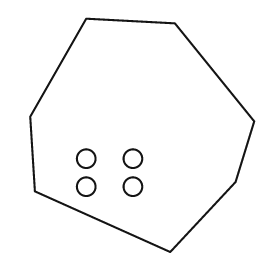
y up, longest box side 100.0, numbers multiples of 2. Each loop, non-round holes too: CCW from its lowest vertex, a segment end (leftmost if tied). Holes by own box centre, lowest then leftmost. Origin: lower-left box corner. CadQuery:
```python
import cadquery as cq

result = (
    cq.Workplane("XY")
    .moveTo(60.0, 0.0)
    .lineTo(88.0, 30.0)
    .lineTo(96.0, 56.0)
    .lineTo(62.0, 98.0)
    .lineTo(24.0, 100.0)
    .lineTo(0.0, 58.0)
    .lineTo(2.0, 26.0)
    .close()
    .moveTo(24.0, 28.0)
    .circle(4.0)
    .moveTo(44.0, 28.0)
    .circle(4.0)
    .moveTo(24.0, 40.0)
    .circle(4.0)
    .moveTo(44.0, 40.0)
    .circle(4.0)
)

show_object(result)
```